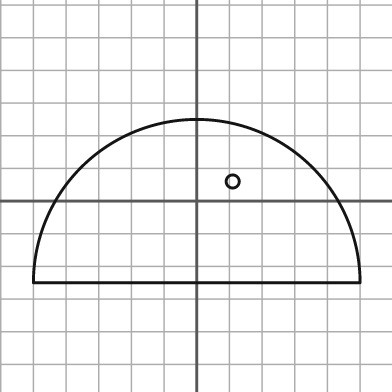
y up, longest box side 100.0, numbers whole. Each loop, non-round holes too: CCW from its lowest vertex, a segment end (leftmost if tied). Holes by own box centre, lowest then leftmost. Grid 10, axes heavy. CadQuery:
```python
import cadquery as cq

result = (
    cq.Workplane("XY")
    .moveTo(-50.0, -25.0)
    .lineTo(50.0, -25.0)
    .threePointArc((0.0, 25.0), (-50.0, -25.0))
    .close()
    .moveTo(11.0, 6.0)
    .circle(2.0)
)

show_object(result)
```